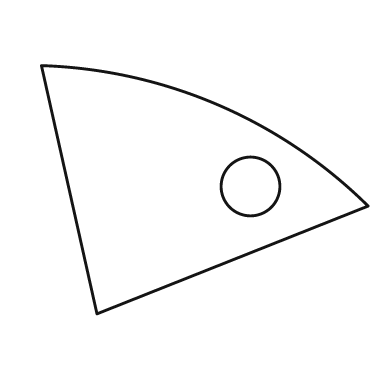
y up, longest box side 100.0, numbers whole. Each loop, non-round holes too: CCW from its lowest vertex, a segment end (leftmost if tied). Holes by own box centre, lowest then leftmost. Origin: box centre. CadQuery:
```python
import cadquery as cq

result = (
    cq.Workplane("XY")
    .moveTo(-33.0, -38.0)
    .lineTo(50.0, -5.0)
    .threePointArc((4.0, 26.0), (-50.0, 38.0))
    .close()
    .moveTo(14.0, 1.0)
    .circle(9.0)
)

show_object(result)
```